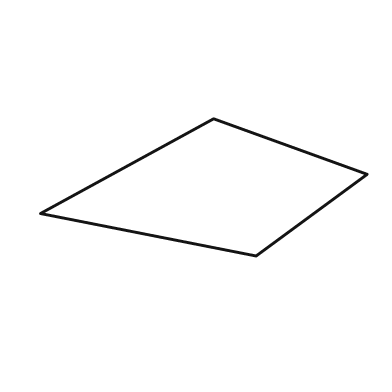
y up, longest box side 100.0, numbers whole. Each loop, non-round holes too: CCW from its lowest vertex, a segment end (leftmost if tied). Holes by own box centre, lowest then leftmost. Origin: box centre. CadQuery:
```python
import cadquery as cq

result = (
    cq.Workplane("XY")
    .moveTo(16.0, -21.0)
    .lineTo(50.0, 4.0)
    .lineTo(3.0, 21.0)
    .lineTo(-50.0, -8.0)
    .close()
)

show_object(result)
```